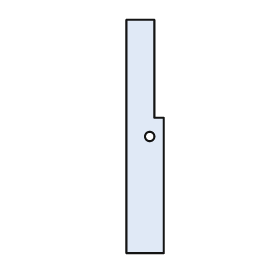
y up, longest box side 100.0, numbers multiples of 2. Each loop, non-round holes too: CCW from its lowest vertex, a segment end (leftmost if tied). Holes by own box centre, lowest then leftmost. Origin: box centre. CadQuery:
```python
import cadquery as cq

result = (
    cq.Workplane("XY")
    .moveTo(-8.0, -50.0)
    .lineTo(8.0, -50.0)
    .lineTo(8.0, 8.0)
    .lineTo(4.0, 8.0)
    .lineTo(4.0, 50.0)
    .lineTo(-8.0, 50.0)
    .close()
    .moveTo(2.0, 0.0)
    .circle(2.0)
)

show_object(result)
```